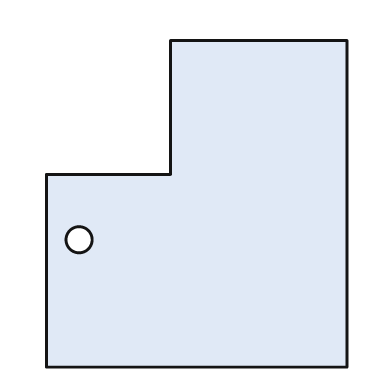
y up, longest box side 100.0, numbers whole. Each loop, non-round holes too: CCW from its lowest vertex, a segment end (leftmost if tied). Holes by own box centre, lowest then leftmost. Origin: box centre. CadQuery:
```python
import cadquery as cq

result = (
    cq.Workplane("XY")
    .moveTo(-46.0, -50.0)
    .lineTo(46.0, -50.0)
    .lineTo(46.0, 50.0)
    .lineTo(-8.0, 50.0)
    .lineTo(-8.0, 9.0)
    .lineTo(-46.0, 9.0)
    .close()
    .moveTo(-36.0, -11.0)
    .circle(4.0)
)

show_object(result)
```